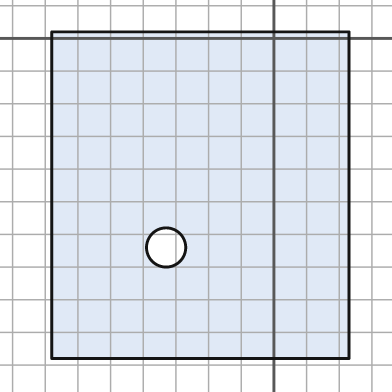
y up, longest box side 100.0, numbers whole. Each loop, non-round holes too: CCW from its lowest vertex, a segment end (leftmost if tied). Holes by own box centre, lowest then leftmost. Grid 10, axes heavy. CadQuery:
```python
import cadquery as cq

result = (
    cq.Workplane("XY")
    .moveTo(-68.0, -98.0)
    .lineTo(23.0, -98.0)
    .lineTo(23.0, 2.0)
    .lineTo(-68.0, 2.0)
    .close()
    .moveTo(-33.0, -64.0)
    .circle(6.0)
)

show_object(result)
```